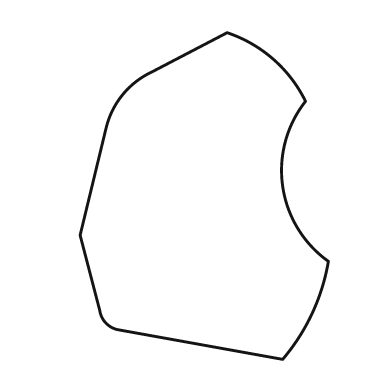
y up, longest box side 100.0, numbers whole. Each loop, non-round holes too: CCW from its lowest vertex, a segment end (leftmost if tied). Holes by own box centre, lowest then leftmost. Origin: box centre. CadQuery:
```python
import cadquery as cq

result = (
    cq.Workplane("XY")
    .moveTo(24.0, -50.0)
    .threePointArc((33.0, -36.0), (38.0, -20.0))
    .threePointArc((24.0, 3.0), (31.0, 29.0))
    .threePointArc((21.0, 42.0), (7.0, 50.0))
    .lineTo(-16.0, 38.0)
    .threePointArc((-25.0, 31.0), (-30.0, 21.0))
    .lineTo(-38.0, -12.0)
    .lineTo(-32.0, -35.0)
    .threePointArc((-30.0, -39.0), (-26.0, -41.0))
    .close()
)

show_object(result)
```